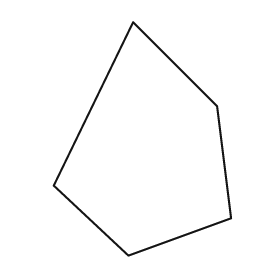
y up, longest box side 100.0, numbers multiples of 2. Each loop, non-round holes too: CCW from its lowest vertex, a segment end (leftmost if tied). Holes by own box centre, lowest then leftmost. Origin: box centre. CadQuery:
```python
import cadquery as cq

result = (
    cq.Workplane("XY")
    .moveTo(-6.0, -50.0)
    .lineTo(38.0, -34.0)
    .lineTo(32.0, 14.0)
    .lineTo(-4.0, 50.0)
    .lineTo(-38.0, -20.0)
    .close()
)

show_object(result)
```